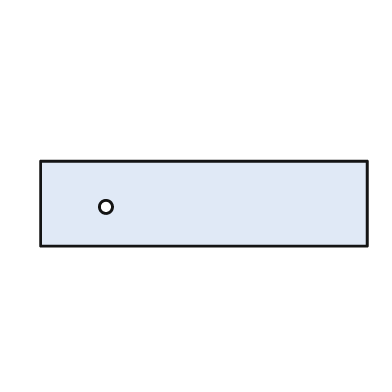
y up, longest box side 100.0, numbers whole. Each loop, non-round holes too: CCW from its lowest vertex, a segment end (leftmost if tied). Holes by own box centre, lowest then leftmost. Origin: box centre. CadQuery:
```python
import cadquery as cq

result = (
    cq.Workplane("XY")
    .moveTo(-50.0, -13.0)
    .lineTo(50.0, -13.0)
    .lineTo(50.0, 13.0)
    .lineTo(-50.0, 13.0)
    .close()
    .moveTo(-30.0, -1.0)
    .circle(2.0)
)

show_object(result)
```